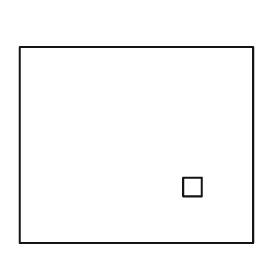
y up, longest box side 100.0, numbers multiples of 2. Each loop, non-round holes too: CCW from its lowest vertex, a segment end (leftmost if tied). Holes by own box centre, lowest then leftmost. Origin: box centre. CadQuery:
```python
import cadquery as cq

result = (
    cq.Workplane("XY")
    .moveTo(-50.0, -42.0)
    .lineTo(50.0, -42.0)
    .lineTo(50.0, 42.0)
    .lineTo(-50.0, 42.0)
    .close()
    .moveTo(20.0, -22.0)
    .lineTo(28.0, -22.0)
    .lineTo(28.0, -14.0)
    .lineTo(20.0, -14.0)
    .close()
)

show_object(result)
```